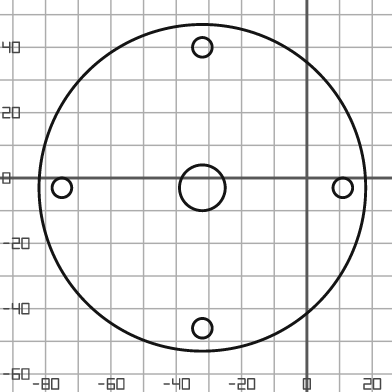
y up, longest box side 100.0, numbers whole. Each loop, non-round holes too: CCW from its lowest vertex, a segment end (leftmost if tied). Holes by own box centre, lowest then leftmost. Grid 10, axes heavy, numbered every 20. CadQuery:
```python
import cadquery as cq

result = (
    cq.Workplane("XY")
    .moveTo(-32.0, -3.0)
    .circle(50.0)
    .moveTo(-32.0, -46.0)
    .circle(3.0)
    .moveTo(-75.0, -3.0)
    .circle(3.0)
    .moveTo(-32.0, -3.0)
    .circle(7.0)
    .moveTo(11.0, -3.0)
    .circle(3.0)
    .moveTo(-32.0, 40.0)
    .circle(3.0)
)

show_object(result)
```